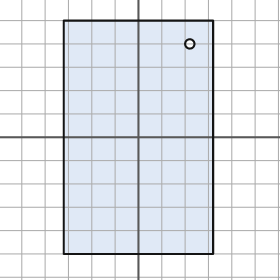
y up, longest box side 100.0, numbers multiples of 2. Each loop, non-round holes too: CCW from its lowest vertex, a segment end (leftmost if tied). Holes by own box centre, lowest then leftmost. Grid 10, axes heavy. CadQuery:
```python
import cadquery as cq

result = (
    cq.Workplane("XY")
    .moveTo(-32.0, -50.0)
    .lineTo(32.0, -50.0)
    .lineTo(32.0, 50.0)
    .lineTo(-32.0, 50.0)
    .close()
    .moveTo(22.0, 40.0)
    .circle(2.0)
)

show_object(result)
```